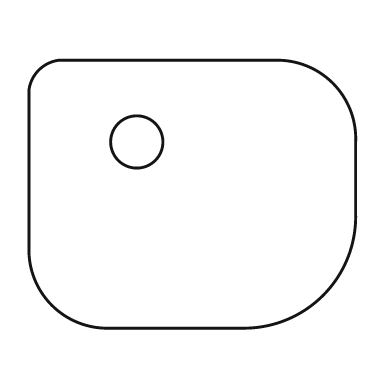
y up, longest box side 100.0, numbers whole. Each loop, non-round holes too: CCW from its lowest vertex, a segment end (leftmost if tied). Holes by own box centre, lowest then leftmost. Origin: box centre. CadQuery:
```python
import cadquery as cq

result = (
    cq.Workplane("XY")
    .moveTo(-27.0, -41.0)
    .lineTo(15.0, -41.0)
    .threePointArc((40.0, -31.0), (50.0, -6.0))
    .lineTo(50.0, 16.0)
    .threePointArc((43.0, 34.0), (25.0, 41.0))
    .lineTo(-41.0, 41.0)
    .threePointArc((-47.0, 38.0), (-50.0, 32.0))
    .lineTo(-50.0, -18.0)
    .threePointArc((-43.0, -34.0), (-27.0, -41.0))
    .close()
    .moveTo(-17.0, 16.0)
    .circle(8.0)
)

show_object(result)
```